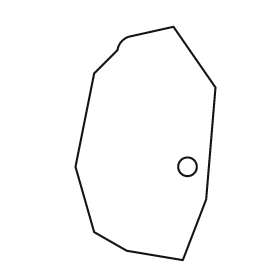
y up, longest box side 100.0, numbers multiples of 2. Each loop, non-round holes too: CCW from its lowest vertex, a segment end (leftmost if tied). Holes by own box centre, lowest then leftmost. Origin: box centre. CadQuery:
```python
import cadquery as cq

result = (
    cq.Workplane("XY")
    .moveTo(16.0, -50.0)
    .lineTo(26.0, -24.0)
    .lineTo(30.0, 24.0)
    .lineTo(12.0, 50.0)
    .lineTo(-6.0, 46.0)
    .threePointArc((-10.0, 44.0), (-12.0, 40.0))
    .lineTo(-22.0, 30.0)
    .lineTo(-30.0, -10.0)
    .lineTo(-22.0, -38.0)
    .lineTo(-8.0, -46.0)
    .close()
    .moveTo(18.0, -10.0)
    .circle(4.0)
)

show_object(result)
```